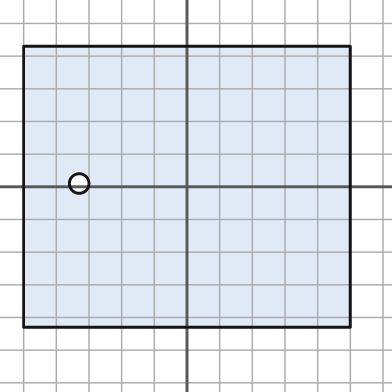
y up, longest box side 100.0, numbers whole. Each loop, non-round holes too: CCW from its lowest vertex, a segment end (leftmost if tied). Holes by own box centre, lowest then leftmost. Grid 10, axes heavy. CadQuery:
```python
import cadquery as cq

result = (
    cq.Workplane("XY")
    .moveTo(-50.0, -43.0)
    .lineTo(50.0, -43.0)
    .lineTo(50.0, 43.0)
    .lineTo(-50.0, 43.0)
    .close()
    .moveTo(-33.0, 1.0)
    .circle(3.0)
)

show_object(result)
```